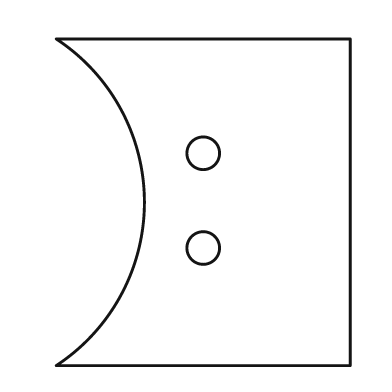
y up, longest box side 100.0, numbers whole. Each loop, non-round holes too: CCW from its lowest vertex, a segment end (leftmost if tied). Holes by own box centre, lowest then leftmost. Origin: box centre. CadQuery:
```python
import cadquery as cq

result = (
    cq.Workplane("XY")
    .moveTo(-45.0, -50.0)
    .lineTo(45.0, -50.0)
    .lineTo(45.0, 50.0)
    .lineTo(-45.0, 50.0)
    .threePointArc((-18.0, 0.0), (-45.0, -50.0))
    .close()
    .moveTo(0.0, -14.0)
    .circle(5.0)
    .moveTo(0.0, 15.0)
    .circle(5.0)
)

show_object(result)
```